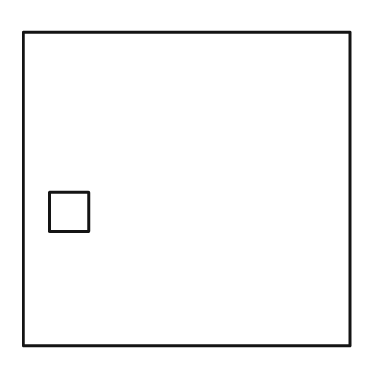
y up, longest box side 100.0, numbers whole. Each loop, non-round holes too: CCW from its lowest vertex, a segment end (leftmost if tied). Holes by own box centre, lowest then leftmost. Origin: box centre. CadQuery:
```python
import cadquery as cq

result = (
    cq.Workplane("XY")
    .moveTo(-50.0, -48.0)
    .lineTo(50.0, -48.0)
    .lineTo(50.0, 48.0)
    .lineTo(-50.0, 48.0)
    .close()
    .moveTo(-42.0, -13.0)
    .lineTo(-30.0, -13.0)
    .lineTo(-30.0, -1.0)
    .lineTo(-42.0, -1.0)
    .close()
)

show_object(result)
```